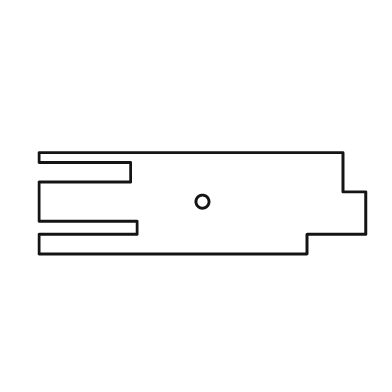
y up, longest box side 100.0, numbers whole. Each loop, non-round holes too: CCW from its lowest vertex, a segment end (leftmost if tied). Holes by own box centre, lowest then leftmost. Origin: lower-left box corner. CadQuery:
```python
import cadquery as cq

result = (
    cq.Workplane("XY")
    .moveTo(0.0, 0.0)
    .lineTo(82.0, 0.0)
    .lineTo(82.0, 6.0)
    .lineTo(100.0, 6.0)
    .lineTo(100.0, 19.0)
    .lineTo(93.0, 19.0)
    .lineTo(93.0, 31.0)
    .lineTo(0.0, 31.0)
    .lineTo(0.0, 28.0)
    .lineTo(28.0, 28.0)
    .lineTo(28.0, 22.0)
    .lineTo(0.0, 22.0)
    .lineTo(0.0, 10.0)
    .lineTo(30.0, 10.0)
    .lineTo(30.0, 6.0)
    .lineTo(0.0, 6.0)
    .close()
    .moveTo(50.0, 16.0)
    .circle(2.0)
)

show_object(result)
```